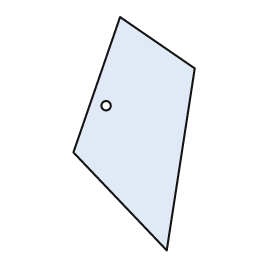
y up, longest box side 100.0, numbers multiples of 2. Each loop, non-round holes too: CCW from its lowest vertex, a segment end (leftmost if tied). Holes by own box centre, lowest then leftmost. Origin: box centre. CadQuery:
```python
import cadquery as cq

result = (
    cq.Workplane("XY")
    .moveTo(14.0, -50.0)
    .lineTo(26.0, 28.0)
    .lineTo(-6.0, 50.0)
    .lineTo(-26.0, -8.0)
    .close()
    .moveTo(-12.0, 12.0)
    .circle(2.0)
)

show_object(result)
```